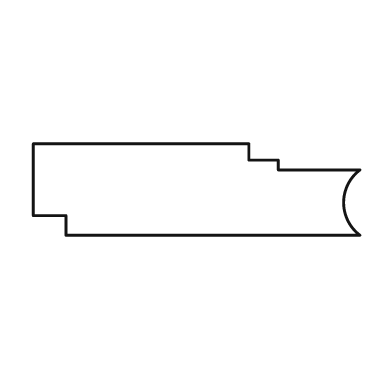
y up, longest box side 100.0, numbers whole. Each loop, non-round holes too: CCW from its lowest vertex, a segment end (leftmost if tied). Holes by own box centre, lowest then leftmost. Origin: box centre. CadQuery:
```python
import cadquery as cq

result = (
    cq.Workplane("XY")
    .moveTo(-40.0, -14.0)
    .lineTo(50.0, -14.0)
    .threePointArc((45.0, -4.0), (50.0, 6.0))
    .lineTo(25.0, 6.0)
    .lineTo(25.0, 9.0)
    .lineTo(16.0, 9.0)
    .lineTo(16.0, 14.0)
    .lineTo(-50.0, 14.0)
    .lineTo(-50.0, -8.0)
    .lineTo(-40.0, -8.0)
    .close()
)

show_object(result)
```